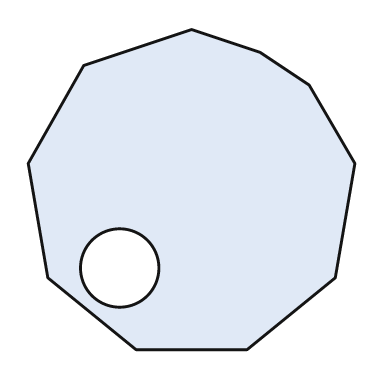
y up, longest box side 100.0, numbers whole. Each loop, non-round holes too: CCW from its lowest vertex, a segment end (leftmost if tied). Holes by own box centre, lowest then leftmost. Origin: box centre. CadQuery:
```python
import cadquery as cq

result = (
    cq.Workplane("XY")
    .moveTo(-17.0, -49.0)
    .lineTo(17.0, -49.0)
    .lineTo(44.0, -27.0)
    .lineTo(50.0, 8.0)
    .lineTo(36.0, 32.0)
    .lineTo(21.0, 42.0)
    .lineTo(0.0, 49.0)
    .lineTo(-33.0, 38.0)
    .lineTo(-50.0, 8.0)
    .lineTo(-44.0, -27.0)
    .close()
    .moveTo(-22.0, -24.0)
    .circle(12.0)
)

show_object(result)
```